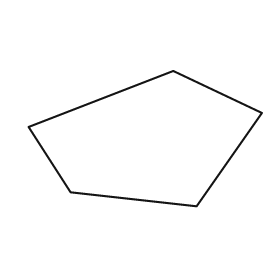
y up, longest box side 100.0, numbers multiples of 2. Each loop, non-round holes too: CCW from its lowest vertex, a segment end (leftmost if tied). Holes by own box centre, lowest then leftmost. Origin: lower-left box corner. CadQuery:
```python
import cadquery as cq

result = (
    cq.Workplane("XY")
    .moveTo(72.0, 0.0)
    .lineTo(100.0, 40.0)
    .lineTo(62.0, 58.0)
    .lineTo(0.0, 34.0)
    .lineTo(18.0, 6.0)
    .close()
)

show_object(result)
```